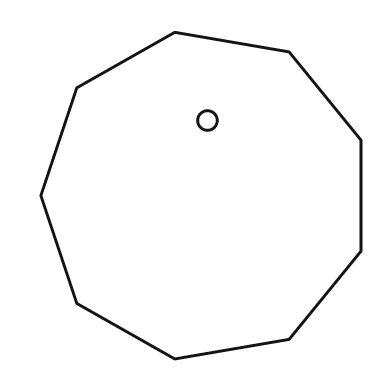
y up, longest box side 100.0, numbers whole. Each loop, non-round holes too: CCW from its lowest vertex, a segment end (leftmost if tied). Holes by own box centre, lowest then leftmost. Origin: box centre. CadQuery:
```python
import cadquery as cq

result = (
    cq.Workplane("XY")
    .moveTo(-8.0, -50.0)
    .lineTo(27.0, -44.0)
    .lineTo(49.0, -17.0)
    .lineTo(49.0, 17.0)
    .lineTo(27.0, 44.0)
    .lineTo(-8.0, 50.0)
    .lineTo(-38.0, 33.0)
    .lineTo(-49.0, 0.0)
    .lineTo(-38.0, -33.0)
    .close()
    .moveTo(2.0, 23.0)
    .circle(3.0)
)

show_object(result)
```